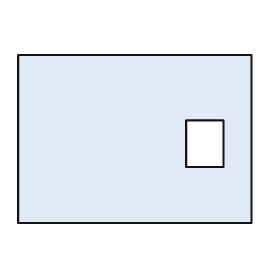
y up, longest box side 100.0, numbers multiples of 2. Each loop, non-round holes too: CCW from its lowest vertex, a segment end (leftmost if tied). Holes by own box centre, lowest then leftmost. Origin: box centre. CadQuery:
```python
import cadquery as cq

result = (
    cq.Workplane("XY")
    .moveTo(-50.0, -36.0)
    .lineTo(50.0, -36.0)
    .lineTo(50.0, 36.0)
    .lineTo(-50.0, 36.0)
    .close()
    .moveTo(22.0, -12.0)
    .lineTo(38.0, -12.0)
    .lineTo(38.0, 8.0)
    .lineTo(22.0, 8.0)
    .close()
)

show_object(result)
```